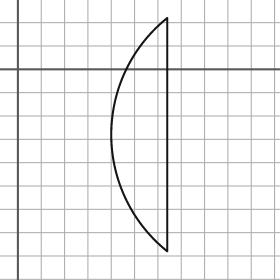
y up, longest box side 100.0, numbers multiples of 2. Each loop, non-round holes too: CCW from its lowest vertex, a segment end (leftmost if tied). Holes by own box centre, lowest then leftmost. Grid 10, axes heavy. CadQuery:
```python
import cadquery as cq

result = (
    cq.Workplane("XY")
    .moveTo(64.0, -78.0)
    .lineTo(64.0, 22.0)
    .threePointArc((40.0, -28.0), (64.0, -78.0))
    .close()
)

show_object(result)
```